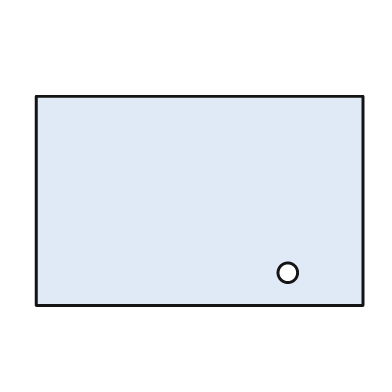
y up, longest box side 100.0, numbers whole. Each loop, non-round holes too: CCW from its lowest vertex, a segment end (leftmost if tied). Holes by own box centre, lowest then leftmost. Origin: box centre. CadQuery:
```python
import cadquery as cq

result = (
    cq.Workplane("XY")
    .moveTo(-50.0, -32.0)
    .lineTo(50.0, -32.0)
    .lineTo(50.0, 32.0)
    .lineTo(-50.0, 32.0)
    .close()
    .moveTo(27.0, -22.0)
    .circle(3.0)
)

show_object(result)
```